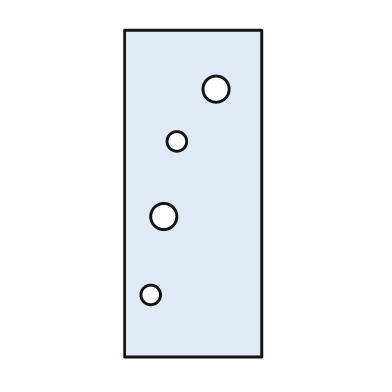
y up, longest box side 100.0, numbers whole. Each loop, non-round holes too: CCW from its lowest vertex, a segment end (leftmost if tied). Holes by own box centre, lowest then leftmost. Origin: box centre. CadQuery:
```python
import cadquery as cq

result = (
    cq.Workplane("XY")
    .moveTo(-21.0, -50.0)
    .lineTo(21.0, -50.0)
    .lineTo(21.0, 50.0)
    .lineTo(-21.0, 50.0)
    .close()
    .moveTo(-13.0, -31.0)
    .circle(3.0)
    .moveTo(-9.0, -7.0)
    .circle(4.0)
    .moveTo(-5.0, 16.0)
    .circle(3.0)
    .moveTo(7.0, 32.0)
    .circle(4.0)
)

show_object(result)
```